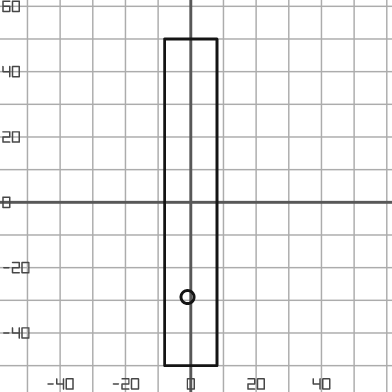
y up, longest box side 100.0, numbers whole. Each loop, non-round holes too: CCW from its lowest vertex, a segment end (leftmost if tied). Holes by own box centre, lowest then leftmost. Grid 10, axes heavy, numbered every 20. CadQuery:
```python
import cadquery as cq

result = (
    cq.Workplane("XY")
    .moveTo(-8.0, -50.0)
    .lineTo(8.0, -50.0)
    .lineTo(8.0, 50.0)
    .lineTo(-8.0, 50.0)
    .close()
    .moveTo(-1.0, -29.0)
    .circle(2.0)
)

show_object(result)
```